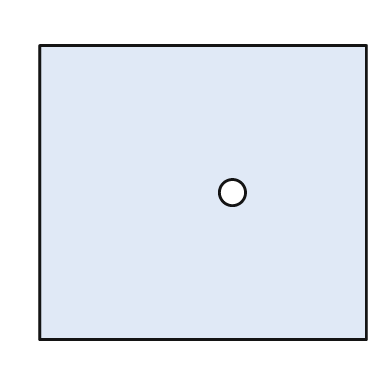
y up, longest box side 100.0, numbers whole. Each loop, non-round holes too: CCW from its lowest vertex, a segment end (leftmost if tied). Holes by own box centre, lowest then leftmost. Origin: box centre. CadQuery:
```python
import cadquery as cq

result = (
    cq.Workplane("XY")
    .moveTo(-50.0, -45.0)
    .lineTo(50.0, -45.0)
    .lineTo(50.0, 45.0)
    .lineTo(-50.0, 45.0)
    .close()
    .moveTo(9.0, 0.0)
    .circle(4.0)
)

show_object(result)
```